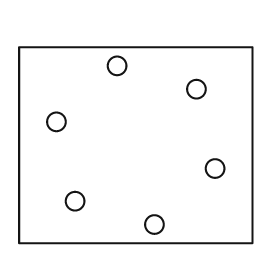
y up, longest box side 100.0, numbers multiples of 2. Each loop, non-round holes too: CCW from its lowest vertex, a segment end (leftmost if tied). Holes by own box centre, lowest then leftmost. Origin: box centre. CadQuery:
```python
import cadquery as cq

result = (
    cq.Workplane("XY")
    .moveTo(-50.0, -42.0)
    .lineTo(50.0, -42.0)
    .lineTo(50.0, 42.0)
    .lineTo(-50.0, 42.0)
    .close()
    .moveTo(8.0, -34.0)
    .circle(4.0)
    .moveTo(-26.0, -24.0)
    .circle(4.0)
    .moveTo(34.0, -10.0)
    .circle(4.0)
    .moveTo(-34.0, 10.0)
    .circle(4.0)
    .moveTo(26.0, 24.0)
    .circle(4.0)
    .moveTo(-8.0, 34.0)
    .circle(4.0)
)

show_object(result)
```